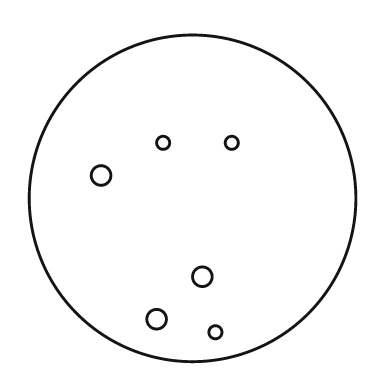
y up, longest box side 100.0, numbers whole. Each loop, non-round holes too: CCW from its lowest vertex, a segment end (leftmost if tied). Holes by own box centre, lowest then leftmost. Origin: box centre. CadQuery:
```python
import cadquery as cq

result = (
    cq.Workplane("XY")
    .moveTo(0.0, 0.0)
    .circle(50.0)
    .moveTo(7.0, -41.0)
    .circle(2.0)
    .moveTo(-11.0, -37.0)
    .circle(3.0)
    .moveTo(3.0, -24.0)
    .circle(3.0)
    .moveTo(-28.0, 7.0)
    .circle(3.0)
    .moveTo(-9.0, 17.0)
    .circle(2.0)
    .moveTo(12.0, 17.0)
    .circle(2.0)
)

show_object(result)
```